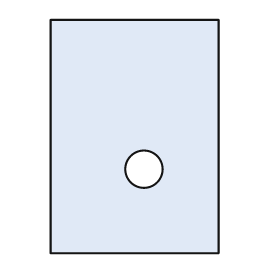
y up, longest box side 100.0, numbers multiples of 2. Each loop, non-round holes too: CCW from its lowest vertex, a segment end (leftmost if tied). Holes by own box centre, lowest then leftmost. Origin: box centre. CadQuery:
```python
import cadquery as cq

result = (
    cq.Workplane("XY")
    .moveTo(-36.0, -50.0)
    .lineTo(36.0, -50.0)
    .lineTo(36.0, 50.0)
    .lineTo(-36.0, 50.0)
    .close()
    .moveTo(4.0, -14.0)
    .circle(8.0)
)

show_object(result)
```